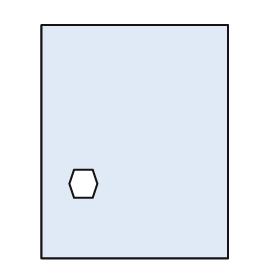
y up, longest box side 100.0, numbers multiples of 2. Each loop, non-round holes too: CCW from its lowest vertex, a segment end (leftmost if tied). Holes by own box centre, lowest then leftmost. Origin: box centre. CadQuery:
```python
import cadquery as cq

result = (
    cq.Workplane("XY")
    .moveTo(-40.0, -50.0)
    .lineTo(40.0, -50.0)
    .lineTo(40.0, 50.0)
    .lineTo(-40.0, 50.0)
    .close()
    .moveTo(-26.0, -24.0)
    .lineTo(-18.0, -24.0)
    .lineTo(-16.0, -18.0)
    .lineTo(-18.0, -12.0)
    .lineTo(-26.0, -12.0)
    .lineTo(-28.0, -18.0)
    .close()
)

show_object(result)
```